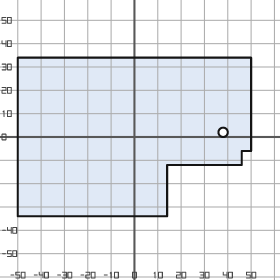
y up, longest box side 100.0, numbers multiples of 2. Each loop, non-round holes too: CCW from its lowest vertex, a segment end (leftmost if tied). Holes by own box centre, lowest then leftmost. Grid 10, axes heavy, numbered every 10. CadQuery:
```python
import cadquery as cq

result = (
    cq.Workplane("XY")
    .moveTo(-50.0, -34.0)
    .lineTo(14.0, -34.0)
    .lineTo(14.0, -12.0)
    .lineTo(46.0, -12.0)
    .lineTo(46.0, -6.0)
    .lineTo(50.0, -6.0)
    .lineTo(50.0, 34.0)
    .lineTo(-50.0, 34.0)
    .close()
    .moveTo(38.0, 2.0)
    .circle(2.0)
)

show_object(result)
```